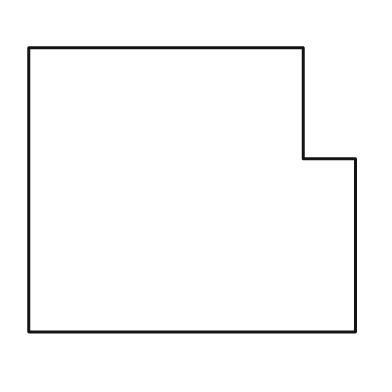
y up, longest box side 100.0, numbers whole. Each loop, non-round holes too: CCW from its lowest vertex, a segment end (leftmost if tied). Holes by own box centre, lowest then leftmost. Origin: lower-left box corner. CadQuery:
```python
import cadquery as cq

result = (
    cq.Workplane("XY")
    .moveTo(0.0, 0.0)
    .lineTo(100.0, 0.0)
    .lineTo(100.0, 53.0)
    .lineTo(84.0, 53.0)
    .lineTo(84.0, 87.0)
    .lineTo(0.0, 87.0)
    .close()
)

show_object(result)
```